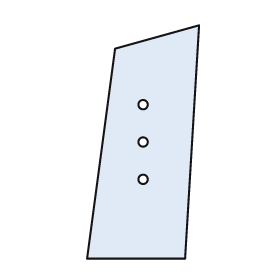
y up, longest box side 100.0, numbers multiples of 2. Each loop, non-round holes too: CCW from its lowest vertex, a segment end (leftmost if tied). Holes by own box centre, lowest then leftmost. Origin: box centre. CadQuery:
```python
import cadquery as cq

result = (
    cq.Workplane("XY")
    .moveTo(-24.0, -50.0)
    .lineTo(18.0, -50.0)
    .lineTo(24.0, 50.0)
    .lineTo(-12.0, 40.0)
    .close()
    .moveTo(0.0, -16.0)
    .circle(2.0)
    .moveTo(0.0, 0.0)
    .circle(2.0)
    .moveTo(0.0, 16.0)
    .circle(2.0)
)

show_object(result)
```